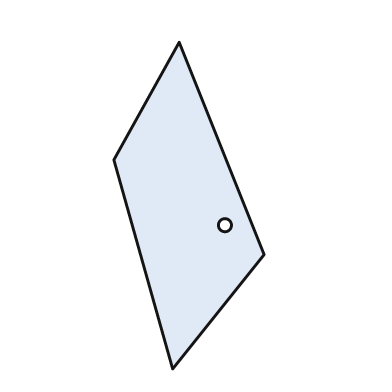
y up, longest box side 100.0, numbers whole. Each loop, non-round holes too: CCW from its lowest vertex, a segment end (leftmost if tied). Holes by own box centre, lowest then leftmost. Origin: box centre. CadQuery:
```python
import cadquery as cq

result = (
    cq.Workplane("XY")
    .moveTo(-5.0, -50.0)
    .lineTo(23.0, -15.0)
    .lineTo(-3.0, 50.0)
    .lineTo(-23.0, 14.0)
    .close()
    .moveTo(11.0, -6.0)
    .circle(2.0)
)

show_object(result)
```